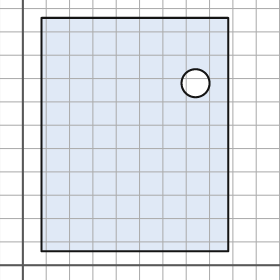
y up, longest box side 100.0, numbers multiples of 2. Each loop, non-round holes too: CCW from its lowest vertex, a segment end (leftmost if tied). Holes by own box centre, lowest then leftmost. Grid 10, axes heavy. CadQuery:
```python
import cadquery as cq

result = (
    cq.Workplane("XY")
    .moveTo(8.0, 6.0)
    .lineTo(88.0, 6.0)
    .lineTo(88.0, 106.0)
    .lineTo(8.0, 106.0)
    .close()
    .moveTo(74.0, 78.0)
    .circle(6.0)
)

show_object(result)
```